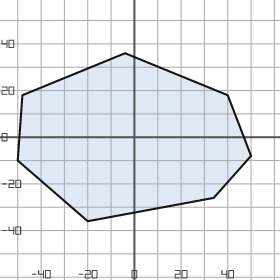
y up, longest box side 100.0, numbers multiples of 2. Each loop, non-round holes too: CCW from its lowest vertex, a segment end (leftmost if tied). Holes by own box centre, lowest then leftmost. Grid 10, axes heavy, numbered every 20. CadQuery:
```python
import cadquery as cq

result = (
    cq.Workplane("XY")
    .moveTo(-20.0, -36.0)
    .lineTo(34.0, -26.0)
    .lineTo(50.0, -8.0)
    .lineTo(40.0, 18.0)
    .lineTo(-4.0, 36.0)
    .lineTo(-48.0, 18.0)
    .lineTo(-50.0, -10.0)
    .close()
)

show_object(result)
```